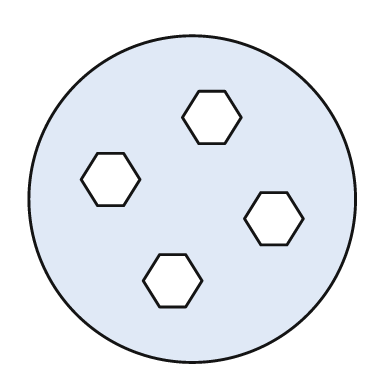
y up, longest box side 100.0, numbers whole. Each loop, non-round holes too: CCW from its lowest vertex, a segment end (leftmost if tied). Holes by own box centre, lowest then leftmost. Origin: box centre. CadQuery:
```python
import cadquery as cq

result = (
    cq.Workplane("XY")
    .moveTo(0.0, 0.0)
    .circle(50.0)
    .moveTo(-10.0, -33.0)
    .lineTo(-2.0, -33.0)
    .lineTo(3.0, -25.0)
    .lineTo(-2.0, -17.0)
    .lineTo(-10.0, -17.0)
    .lineTo(-15.0, -25.0)
    .close()
    .moveTo(21.0, -14.0)
    .lineTo(29.0, -14.0)
    .lineTo(34.0, -6.0)
    .lineTo(29.0, 2.0)
    .lineTo(21.0, 2.0)
    .lineTo(16.0, -6.0)
    .close()
    .moveTo(-29.0, -2.0)
    .lineTo(-21.0, -2.0)
    .lineTo(-16.0, 6.0)
    .lineTo(-21.0, 14.0)
    .lineTo(-29.0, 14.0)
    .lineTo(-34.0, 6.0)
    .close()
    .moveTo(2.0, 17.0)
    .lineTo(10.0, 17.0)
    .lineTo(15.0, 25.0)
    .lineTo(10.0, 33.0)
    .lineTo(2.0, 33.0)
    .lineTo(-3.0, 25.0)
    .close()
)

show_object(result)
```